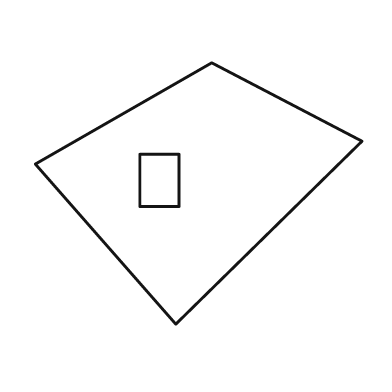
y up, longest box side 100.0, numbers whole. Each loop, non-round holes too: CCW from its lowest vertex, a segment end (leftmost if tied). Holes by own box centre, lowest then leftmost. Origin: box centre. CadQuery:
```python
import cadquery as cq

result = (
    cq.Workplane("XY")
    .moveTo(-7.0, -40.0)
    .lineTo(50.0, 16.0)
    .lineTo(4.0, 40.0)
    .lineTo(-50.0, 9.0)
    .close()
    .moveTo(-18.0, -4.0)
    .lineTo(-6.0, -4.0)
    .lineTo(-6.0, 12.0)
    .lineTo(-18.0, 12.0)
    .close()
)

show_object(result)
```